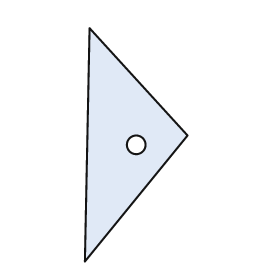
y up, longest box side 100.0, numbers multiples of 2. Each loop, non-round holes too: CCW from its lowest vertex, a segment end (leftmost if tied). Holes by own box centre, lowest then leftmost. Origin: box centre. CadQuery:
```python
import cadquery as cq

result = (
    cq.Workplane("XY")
    .moveTo(-22.0, -50.0)
    .lineTo(22.0, 4.0)
    .lineTo(-20.0, 50.0)
    .close()
    .moveTo(0.0, 0.0)
    .circle(4.0)
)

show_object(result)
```